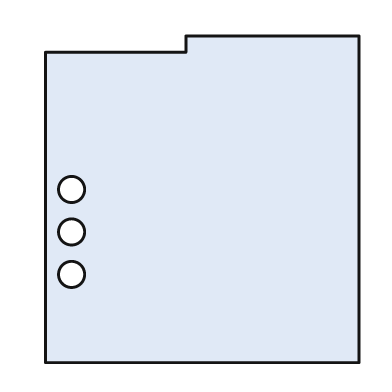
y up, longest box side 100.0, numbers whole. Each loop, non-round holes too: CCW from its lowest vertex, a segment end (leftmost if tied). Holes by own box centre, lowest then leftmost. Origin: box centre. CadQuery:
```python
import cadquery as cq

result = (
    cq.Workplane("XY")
    .moveTo(-48.0, -50.0)
    .lineTo(48.0, -50.0)
    .lineTo(48.0, 50.0)
    .lineTo(-5.0, 50.0)
    .lineTo(-5.0, 45.0)
    .lineTo(-48.0, 45.0)
    .close()
    .moveTo(-40.0, -23.0)
    .circle(4.0)
    .moveTo(-40.0, -10.0)
    .circle(4.0)
    .moveTo(-40.0, 3.0)
    .circle(4.0)
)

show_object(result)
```